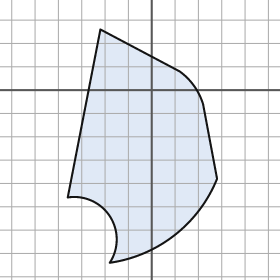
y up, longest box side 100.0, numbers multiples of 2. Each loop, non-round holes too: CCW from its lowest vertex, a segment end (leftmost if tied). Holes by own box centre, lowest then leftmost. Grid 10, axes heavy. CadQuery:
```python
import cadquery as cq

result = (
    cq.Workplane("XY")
    .moveTo(-18.0, -74.0)
    .threePointArc((10.0, -62.0), (28.0, -38.0))
    .lineTo(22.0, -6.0)
    .threePointArc((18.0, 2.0), (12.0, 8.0))
    .lineTo(-22.0, 26.0)
    .lineTo(-36.0, -46.0)
    .threePointArc((-18.0, -54.0), (-18.0, -74.0))
    .close()
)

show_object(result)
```